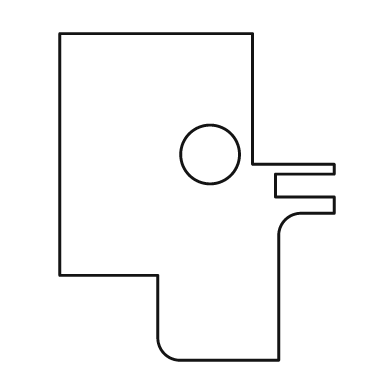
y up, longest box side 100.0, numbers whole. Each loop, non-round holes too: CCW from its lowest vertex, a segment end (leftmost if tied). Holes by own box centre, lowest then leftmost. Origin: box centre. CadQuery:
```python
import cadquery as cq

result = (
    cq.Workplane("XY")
    .moveTo(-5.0, -50.0)
    .lineTo(25.0, -50.0)
    .lineTo(25.0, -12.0)
    .threePointArc((27.0, -7.0), (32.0, -5.0))
    .lineTo(42.0, -5.0)
    .lineTo(42.0, 0.0)
    .lineTo(24.0, 0.0)
    .lineTo(24.0, 7.0)
    .lineTo(42.0, 7.0)
    .lineTo(42.0, 10.0)
    .lineTo(17.0, 10.0)
    .lineTo(17.0, 50.0)
    .lineTo(-42.0, 50.0)
    .lineTo(-42.0, -24.0)
    .lineTo(-12.0, -24.0)
    .lineTo(-12.0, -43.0)
    .threePointArc((-10.0, -48.0), (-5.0, -50.0))
    .close()
    .moveTo(4.0, 13.0)
    .circle(9.0)
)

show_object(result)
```